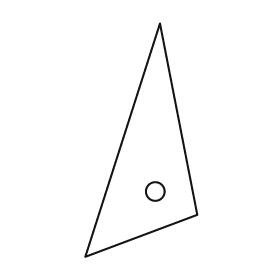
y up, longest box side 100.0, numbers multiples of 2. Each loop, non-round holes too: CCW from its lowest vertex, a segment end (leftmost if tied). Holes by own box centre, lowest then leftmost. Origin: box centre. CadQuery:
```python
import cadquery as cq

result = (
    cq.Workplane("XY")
    .moveTo(-24.0, -50.0)
    .lineTo(24.0, -32.0)
    .lineTo(8.0, 50.0)
    .close()
    .moveTo(6.0, -22.0)
    .circle(4.0)
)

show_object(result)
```